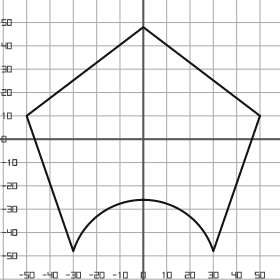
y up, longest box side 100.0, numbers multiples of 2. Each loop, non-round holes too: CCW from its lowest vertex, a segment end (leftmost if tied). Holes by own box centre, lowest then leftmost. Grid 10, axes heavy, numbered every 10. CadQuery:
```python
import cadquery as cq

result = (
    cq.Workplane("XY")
    .moveTo(-30.0, -48.0)
    .threePointArc((0.0, -26.0), (30.0, -48.0))
    .lineTo(50.0, 10.0)
    .lineTo(0.0, 48.0)
    .lineTo(-50.0, 10.0)
    .close()
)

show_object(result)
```